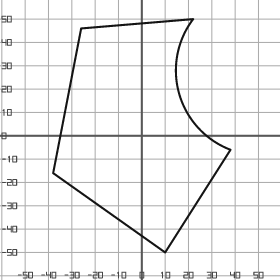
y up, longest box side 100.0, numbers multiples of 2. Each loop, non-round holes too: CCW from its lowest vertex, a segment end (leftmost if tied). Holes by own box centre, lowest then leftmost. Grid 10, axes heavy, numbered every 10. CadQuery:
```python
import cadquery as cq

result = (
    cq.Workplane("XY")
    .moveTo(10.0, -50.0)
    .lineTo(38.0, -6.0)
    .threePointArc((16.0, 18.0), (22.0, 50.0))
    .lineTo(-26.0, 46.0)
    .lineTo(-38.0, -16.0)
    .close()
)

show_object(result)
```